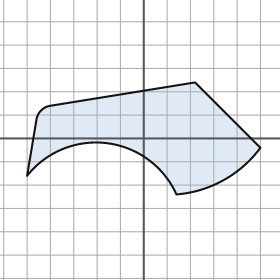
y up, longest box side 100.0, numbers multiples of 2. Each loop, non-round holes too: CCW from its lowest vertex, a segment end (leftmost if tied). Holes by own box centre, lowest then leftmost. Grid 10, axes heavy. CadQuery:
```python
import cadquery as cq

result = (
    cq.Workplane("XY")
    .moveTo(14.0, -24.0)
    .threePointArc((34.0, -18.0), (50.0, -4.0))
    .lineTo(22.0, 24.0)
    .lineTo(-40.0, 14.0)
    .threePointArc((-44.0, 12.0), (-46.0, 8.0))
    .lineTo(-50.0, -16.0)
    .threePointArc((-16.0, -2.0), (14.0, -24.0))
    .close()
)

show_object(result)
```